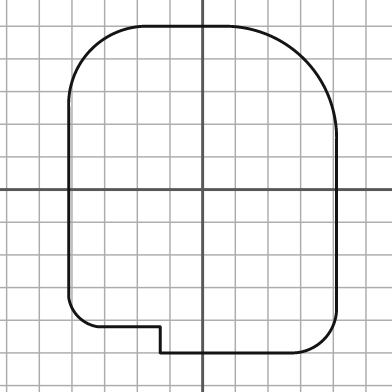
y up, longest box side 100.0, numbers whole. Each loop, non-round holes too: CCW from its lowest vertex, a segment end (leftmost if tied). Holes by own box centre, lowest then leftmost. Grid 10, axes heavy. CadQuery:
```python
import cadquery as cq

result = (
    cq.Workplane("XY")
    .moveTo(-13.0, -50.0)
    .lineTo(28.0, -50.0)
    .threePointArc((37.0, -46.0), (41.0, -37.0))
    .lineTo(41.0, 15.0)
    .threePointArc((31.0, 40.0), (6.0, 50.0))
    .lineTo(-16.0, 50.0)
    .threePointArc((-34.0, 43.0), (-41.0, 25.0))
    .lineTo(-41.0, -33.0)
    .threePointArc((-38.0, -39.0), (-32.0, -42.0))
    .lineTo(-13.0, -42.0)
    .close()
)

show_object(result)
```